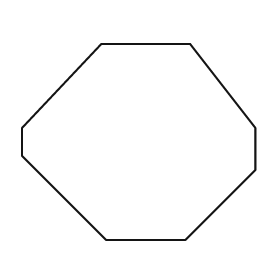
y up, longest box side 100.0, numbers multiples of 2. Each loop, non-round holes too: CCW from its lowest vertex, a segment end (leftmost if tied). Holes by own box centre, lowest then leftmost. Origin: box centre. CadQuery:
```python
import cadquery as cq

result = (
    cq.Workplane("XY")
    .moveTo(-14.0, -42.0)
    .lineTo(20.0, -42.0)
    .lineTo(50.0, -12.0)
    .lineTo(50.0, 6.0)
    .lineTo(22.0, 42.0)
    .lineTo(-16.0, 42.0)
    .lineTo(-50.0, 6.0)
    .lineTo(-50.0, -6.0)
    .close()
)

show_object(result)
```